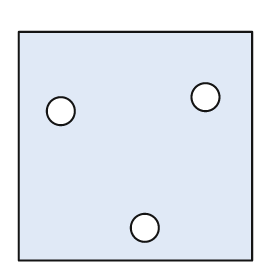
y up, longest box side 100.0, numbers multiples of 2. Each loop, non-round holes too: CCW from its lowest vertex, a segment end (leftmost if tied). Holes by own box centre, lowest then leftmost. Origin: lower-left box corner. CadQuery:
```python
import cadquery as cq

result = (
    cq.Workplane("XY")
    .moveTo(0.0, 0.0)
    .lineTo(100.0, 0.0)
    .lineTo(100.0, 98.0)
    .lineTo(0.0, 98.0)
    .close()
    .moveTo(54.0, 14.0)
    .circle(6.0)
    .moveTo(18.0, 64.0)
    .circle(6.0)
    .moveTo(80.0, 70.0)
    .circle(6.0)
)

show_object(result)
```